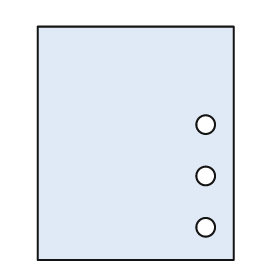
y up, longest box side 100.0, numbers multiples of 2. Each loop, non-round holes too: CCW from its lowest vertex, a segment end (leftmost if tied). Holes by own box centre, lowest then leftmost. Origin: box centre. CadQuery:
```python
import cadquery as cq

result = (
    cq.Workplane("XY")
    .moveTo(-42.0, -50.0)
    .lineTo(42.0, -50.0)
    .lineTo(42.0, 50.0)
    .lineTo(-42.0, 50.0)
    .close()
    .moveTo(30.0, -36.0)
    .circle(4.0)
    .moveTo(30.0, -14.0)
    .circle(4.0)
    .moveTo(30.0, 8.0)
    .circle(4.0)
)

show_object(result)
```